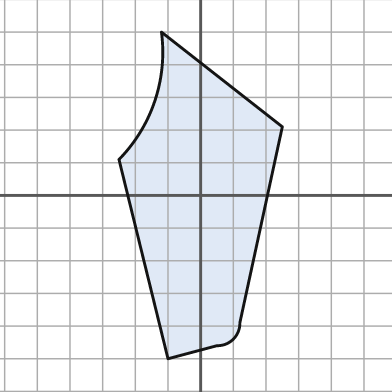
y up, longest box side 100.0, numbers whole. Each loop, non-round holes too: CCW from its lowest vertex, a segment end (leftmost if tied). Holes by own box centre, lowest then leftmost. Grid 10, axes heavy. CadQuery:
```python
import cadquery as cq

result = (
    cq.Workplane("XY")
    .moveTo(-10.0, -50.0)
    .lineTo(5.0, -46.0)
    .threePointArc((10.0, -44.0), (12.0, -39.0))
    .lineTo(25.0, 21.0)
    .lineTo(-12.0, 50.0)
    .threePointArc((-14.0, 29.0), (-25.0, 11.0))
    .close()
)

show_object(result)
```